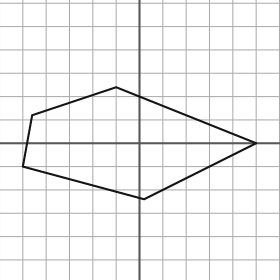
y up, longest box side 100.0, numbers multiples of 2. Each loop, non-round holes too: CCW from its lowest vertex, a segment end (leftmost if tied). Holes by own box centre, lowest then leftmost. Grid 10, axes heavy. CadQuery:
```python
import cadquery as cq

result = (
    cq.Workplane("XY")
    .moveTo(2.0, -24.0)
    .lineTo(50.0, 0.0)
    .lineTo(-10.0, 24.0)
    .lineTo(-46.0, 12.0)
    .lineTo(-50.0, -10.0)
    .close()
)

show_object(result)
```